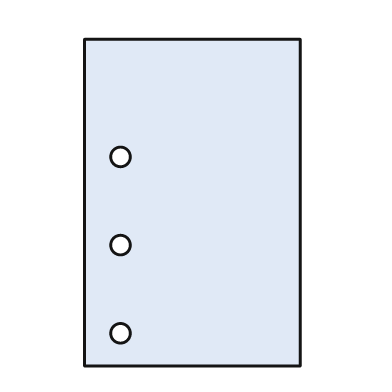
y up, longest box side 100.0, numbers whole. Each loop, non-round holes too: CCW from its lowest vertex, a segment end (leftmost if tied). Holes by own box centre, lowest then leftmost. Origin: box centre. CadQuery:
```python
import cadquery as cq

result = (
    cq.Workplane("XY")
    .moveTo(-33.0, -50.0)
    .lineTo(33.0, -50.0)
    .lineTo(33.0, 50.0)
    .lineTo(-33.0, 50.0)
    .close()
    .moveTo(-22.0, -40.0)
    .circle(3.0)
    .moveTo(-22.0, -13.0)
    .circle(3.0)
    .moveTo(-22.0, 14.0)
    .circle(3.0)
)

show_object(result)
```